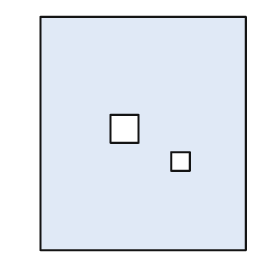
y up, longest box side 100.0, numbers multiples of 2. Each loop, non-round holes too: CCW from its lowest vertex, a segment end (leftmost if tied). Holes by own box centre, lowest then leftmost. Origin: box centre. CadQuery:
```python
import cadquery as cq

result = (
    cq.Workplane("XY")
    .moveTo(-44.0, -50.0)
    .lineTo(44.0, -50.0)
    .lineTo(44.0, 50.0)
    .lineTo(-44.0, 50.0)
    .close()
    .moveTo(12.0, -16.0)
    .lineTo(20.0, -16.0)
    .lineTo(20.0, -8.0)
    .lineTo(12.0, -8.0)
    .close()
    .moveTo(-14.0, -4.0)
    .lineTo(-2.0, -4.0)
    .lineTo(-2.0, 8.0)
    .lineTo(-14.0, 8.0)
    .close()
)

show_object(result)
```